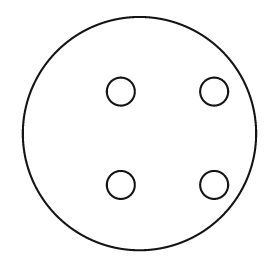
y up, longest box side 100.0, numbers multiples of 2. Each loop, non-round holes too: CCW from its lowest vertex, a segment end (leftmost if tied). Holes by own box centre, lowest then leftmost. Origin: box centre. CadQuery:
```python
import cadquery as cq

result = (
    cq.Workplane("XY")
    .moveTo(0.0, 0.0)
    .circle(50.0)
    .moveTo(-8.0, -22.0)
    .circle(6.0)
    .moveTo(32.0, -22.0)
    .circle(6.0)
    .moveTo(-8.0, 18.0)
    .circle(6.0)
    .moveTo(32.0, 18.0)
    .circle(6.0)
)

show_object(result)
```